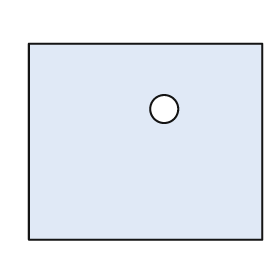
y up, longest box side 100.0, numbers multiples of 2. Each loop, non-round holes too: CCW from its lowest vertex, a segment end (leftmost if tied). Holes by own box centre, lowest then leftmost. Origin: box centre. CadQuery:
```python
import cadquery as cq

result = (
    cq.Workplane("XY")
    .moveTo(-50.0, -42.0)
    .lineTo(50.0, -42.0)
    .lineTo(50.0, 42.0)
    .lineTo(-50.0, 42.0)
    .close()
    .moveTo(8.0, 14.0)
    .circle(6.0)
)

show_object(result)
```